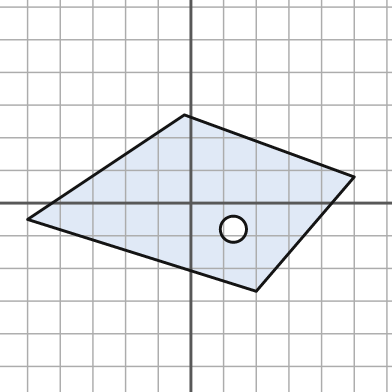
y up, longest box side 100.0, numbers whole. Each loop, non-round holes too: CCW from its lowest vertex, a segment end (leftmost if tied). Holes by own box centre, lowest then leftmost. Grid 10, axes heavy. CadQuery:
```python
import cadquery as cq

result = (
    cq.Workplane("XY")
    .moveTo(20.0, -27.0)
    .lineTo(50.0, 8.0)
    .lineTo(-2.0, 27.0)
    .lineTo(-50.0, -5.0)
    .close()
    .moveTo(13.0, -8.0)
    .circle(4.0)
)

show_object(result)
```